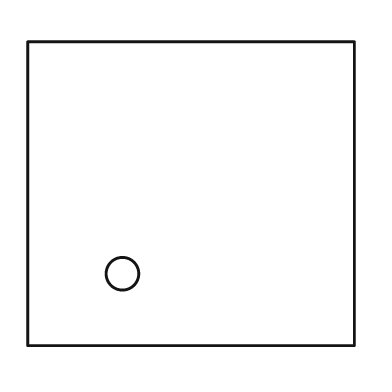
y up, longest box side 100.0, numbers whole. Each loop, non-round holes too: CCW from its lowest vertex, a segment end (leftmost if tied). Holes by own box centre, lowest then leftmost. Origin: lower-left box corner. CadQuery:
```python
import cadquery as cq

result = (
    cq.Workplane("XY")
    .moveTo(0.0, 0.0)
    .lineTo(100.0, 0.0)
    .lineTo(100.0, 93.0)
    .lineTo(0.0, 93.0)
    .close()
    .moveTo(29.0, 22.0)
    .circle(5.0)
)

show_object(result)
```